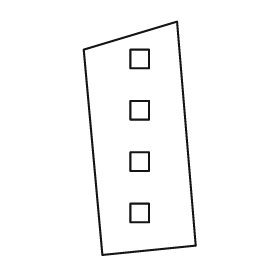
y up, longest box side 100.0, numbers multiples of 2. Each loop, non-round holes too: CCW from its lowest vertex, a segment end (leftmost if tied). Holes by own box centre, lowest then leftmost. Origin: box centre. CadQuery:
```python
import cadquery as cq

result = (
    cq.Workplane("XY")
    .moveTo(-16.0, -50.0)
    .lineTo(24.0, -46.0)
    .lineTo(16.0, 50.0)
    .lineTo(-24.0, 38.0)
    .close()
    .moveTo(-4.0, -36.0)
    .lineTo(4.0, -36.0)
    .lineTo(4.0, -28.0)
    .lineTo(-4.0, -28.0)
    .close()
    .moveTo(-4.0, -14.0)
    .lineTo(4.0, -14.0)
    .lineTo(4.0, -6.0)
    .lineTo(-4.0, -6.0)
    .close()
    .moveTo(-4.0, 8.0)
    .lineTo(4.0, 8.0)
    .lineTo(4.0, 16.0)
    .lineTo(-4.0, 16.0)
    .close()
    .moveTo(-4.0, 30.0)
    .lineTo(4.0, 30.0)
    .lineTo(4.0, 38.0)
    .lineTo(-4.0, 38.0)
    .close()
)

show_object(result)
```